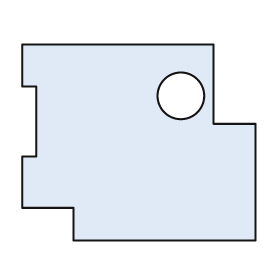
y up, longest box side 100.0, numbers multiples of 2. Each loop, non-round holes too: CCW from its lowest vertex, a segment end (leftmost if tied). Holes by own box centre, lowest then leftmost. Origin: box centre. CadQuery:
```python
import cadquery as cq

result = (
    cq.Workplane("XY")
    .moveTo(-28.0, -42.0)
    .lineTo(50.0, -42.0)
    .lineTo(50.0, 8.0)
    .lineTo(32.0, 8.0)
    .lineTo(32.0, 42.0)
    .lineTo(-50.0, 42.0)
    .lineTo(-50.0, 24.0)
    .lineTo(-44.0, 24.0)
    .lineTo(-44.0, -6.0)
    .lineTo(-50.0, -6.0)
    .lineTo(-50.0, -28.0)
    .lineTo(-28.0, -28.0)
    .close()
    .moveTo(18.0, 20.0)
    .circle(10.0)
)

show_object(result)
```